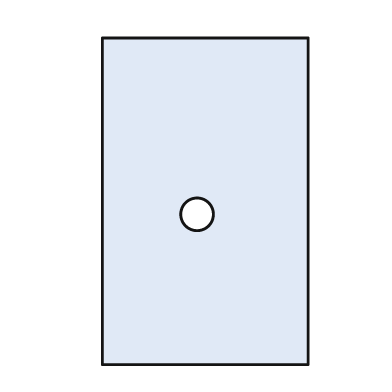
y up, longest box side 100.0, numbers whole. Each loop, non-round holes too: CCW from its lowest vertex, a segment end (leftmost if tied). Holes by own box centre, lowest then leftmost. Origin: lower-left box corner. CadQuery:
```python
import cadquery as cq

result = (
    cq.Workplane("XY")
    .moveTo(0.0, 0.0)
    .lineTo(63.0, 0.0)
    .lineTo(63.0, 100.0)
    .lineTo(0.0, 100.0)
    .close()
    .moveTo(29.0, 46.0)
    .circle(5.0)
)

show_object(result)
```